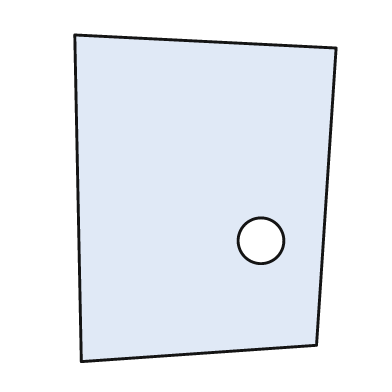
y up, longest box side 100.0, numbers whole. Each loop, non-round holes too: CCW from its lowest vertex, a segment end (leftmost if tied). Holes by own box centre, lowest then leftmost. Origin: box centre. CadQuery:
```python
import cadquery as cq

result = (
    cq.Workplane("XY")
    .moveTo(-38.0, -50.0)
    .lineTo(34.0, -45.0)
    .lineTo(40.0, 46.0)
    .lineTo(-40.0, 50.0)
    .close()
    .moveTo(17.0, -13.0)
    .circle(7.0)
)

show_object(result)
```